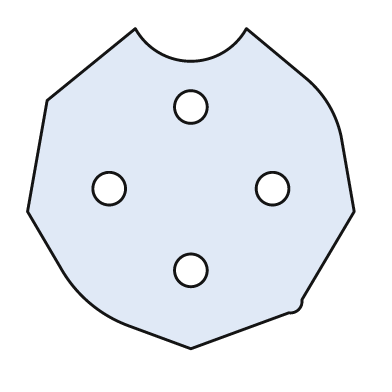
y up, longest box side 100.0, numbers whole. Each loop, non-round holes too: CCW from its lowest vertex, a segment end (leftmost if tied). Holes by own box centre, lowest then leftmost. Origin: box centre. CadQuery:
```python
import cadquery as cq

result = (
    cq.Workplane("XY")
    .moveTo(0.0, -49.0)
    .lineTo(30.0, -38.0)
    .threePointArc((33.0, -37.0), (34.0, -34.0))
    .lineTo(50.0, -7.0)
    .lineTo(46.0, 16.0)
    .threePointArc((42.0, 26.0), (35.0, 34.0))
    .lineTo(17.0, 49.0)
    .threePointArc((0.0, 39.0), (-17.0, 49.0))
    .lineTo(-44.0, 27.0)
    .lineTo(-50.0, -7.0)
    .lineTo(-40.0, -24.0)
    .threePointArc((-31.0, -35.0), (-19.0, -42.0))
    .close()
    .moveTo(0.0, -25.0)
    .circle(5.0)
    .moveTo(-25.0, 0.0)
    .circle(5.0)
    .moveTo(25.0, 0.0)
    .circle(5.0)
    .moveTo(0.0, 25.0)
    .circle(5.0)
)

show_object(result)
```